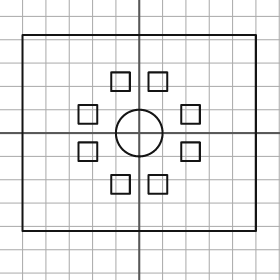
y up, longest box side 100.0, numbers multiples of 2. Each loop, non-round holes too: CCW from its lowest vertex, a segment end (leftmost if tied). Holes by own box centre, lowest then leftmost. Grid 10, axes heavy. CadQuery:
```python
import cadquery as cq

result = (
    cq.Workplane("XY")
    .moveTo(-50.0, -42.0)
    .lineTo(50.0, -42.0)
    .lineTo(50.0, 42.0)
    .lineTo(-50.0, 42.0)
    .close()
    .moveTo(-12.0, -26.0)
    .lineTo(-4.0, -26.0)
    .lineTo(-4.0, -18.0)
    .lineTo(-12.0, -18.0)
    .close()
    .moveTo(4.0, -26.0)
    .lineTo(12.0, -26.0)
    .lineTo(12.0, -18.0)
    .lineTo(4.0, -18.0)
    .close()
    .moveTo(-26.0, -12.0)
    .lineTo(-18.0, -12.0)
    .lineTo(-18.0, -4.0)
    .lineTo(-26.0, -4.0)
    .close()
    .moveTo(18.0, -12.0)
    .lineTo(26.0, -12.0)
    .lineTo(26.0, -4.0)
    .lineTo(18.0, -4.0)
    .close()
    .moveTo(0.0, 0.0)
    .circle(10.0)
    .moveTo(-26.0, 4.0)
    .lineTo(-18.0, 4.0)
    .lineTo(-18.0, 12.0)
    .lineTo(-26.0, 12.0)
    .close()
    .moveTo(18.0, 4.0)
    .lineTo(26.0, 4.0)
    .lineTo(26.0, 12.0)
    .lineTo(18.0, 12.0)
    .close()
    .moveTo(-12.0, 18.0)
    .lineTo(-4.0, 18.0)
    .lineTo(-4.0, 26.0)
    .lineTo(-12.0, 26.0)
    .close()
    .moveTo(4.0, 18.0)
    .lineTo(12.0, 18.0)
    .lineTo(12.0, 26.0)
    .lineTo(4.0, 26.0)
    .close()
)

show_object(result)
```